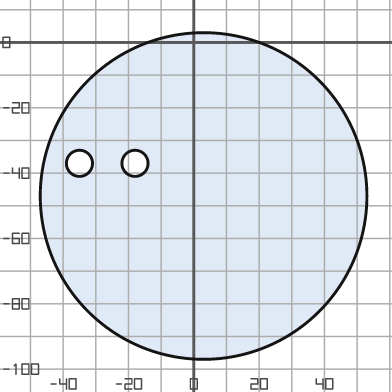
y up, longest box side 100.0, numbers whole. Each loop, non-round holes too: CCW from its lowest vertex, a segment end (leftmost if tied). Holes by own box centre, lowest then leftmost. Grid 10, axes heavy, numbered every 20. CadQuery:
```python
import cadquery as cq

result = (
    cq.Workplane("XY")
    .moveTo(3.0, -47.0)
    .circle(50.0)
    .moveTo(-35.0, -37.0)
    .circle(4.0)
    .moveTo(-18.0, -37.0)
    .circle(4.0)
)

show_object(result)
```